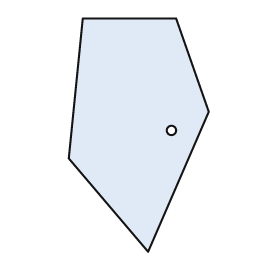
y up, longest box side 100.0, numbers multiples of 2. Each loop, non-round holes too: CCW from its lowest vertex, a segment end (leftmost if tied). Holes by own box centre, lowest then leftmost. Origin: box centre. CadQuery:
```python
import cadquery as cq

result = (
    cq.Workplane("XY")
    .moveTo(4.0, -50.0)
    .lineTo(30.0, 10.0)
    .lineTo(16.0, 50.0)
    .lineTo(-24.0, 50.0)
    .lineTo(-30.0, -10.0)
    .close()
    .moveTo(14.0, 2.0)
    .circle(2.0)
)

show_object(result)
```